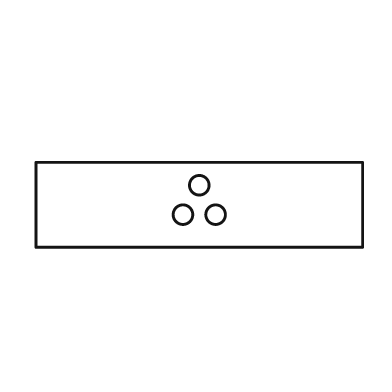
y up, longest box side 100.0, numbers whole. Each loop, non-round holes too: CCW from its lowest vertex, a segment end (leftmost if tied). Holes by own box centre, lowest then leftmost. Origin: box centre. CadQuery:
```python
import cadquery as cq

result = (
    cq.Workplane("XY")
    .moveTo(-50.0, -13.0)
    .lineTo(50.0, -13.0)
    .lineTo(50.0, 13.0)
    .lineTo(-50.0, 13.0)
    .close()
    .moveTo(-5.0, -3.0)
    .circle(3.0)
    .moveTo(5.0, -3.0)
    .circle(3.0)
    .moveTo(0.0, 6.0)
    .circle(3.0)
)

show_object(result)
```